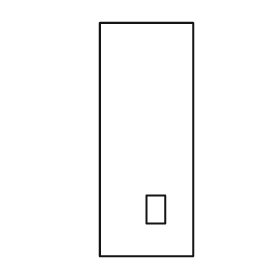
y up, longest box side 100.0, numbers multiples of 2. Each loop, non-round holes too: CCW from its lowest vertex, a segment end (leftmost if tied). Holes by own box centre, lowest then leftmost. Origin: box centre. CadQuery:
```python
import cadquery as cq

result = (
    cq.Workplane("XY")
    .moveTo(-20.0, -50.0)
    .lineTo(20.0, -50.0)
    .lineTo(20.0, 50.0)
    .lineTo(-20.0, 50.0)
    .close()
    .moveTo(0.0, -36.0)
    .lineTo(8.0, -36.0)
    .lineTo(8.0, -24.0)
    .lineTo(0.0, -24.0)
    .close()
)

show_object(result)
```